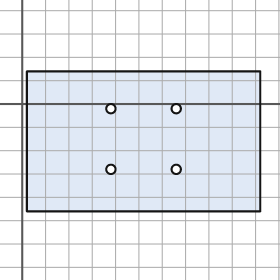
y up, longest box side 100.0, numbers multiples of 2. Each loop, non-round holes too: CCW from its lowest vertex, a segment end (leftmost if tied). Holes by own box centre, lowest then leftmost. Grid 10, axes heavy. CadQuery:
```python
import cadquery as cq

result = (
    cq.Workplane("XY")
    .moveTo(2.0, -46.0)
    .lineTo(102.0, -46.0)
    .lineTo(102.0, 14.0)
    .lineTo(2.0, 14.0)
    .close()
    .moveTo(38.0, -28.0)
    .circle(2.0)
    .moveTo(66.0, -28.0)
    .circle(2.0)
    .moveTo(38.0, -2.0)
    .circle(2.0)
    .moveTo(66.0, -2.0)
    .circle(2.0)
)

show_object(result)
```